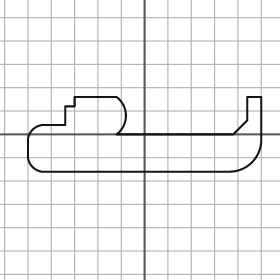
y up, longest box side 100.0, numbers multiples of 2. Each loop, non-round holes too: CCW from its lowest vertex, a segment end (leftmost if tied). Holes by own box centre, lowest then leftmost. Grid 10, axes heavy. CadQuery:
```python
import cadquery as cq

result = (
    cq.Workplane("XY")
    .moveTo(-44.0, -16.0)
    .lineTo(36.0, -16.0)
    .threePointArc((46.0, -12.0), (50.0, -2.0))
    .lineTo(50.0, 16.0)
    .lineTo(44.0, 16.0)
    .lineTo(44.0, 6.0)
    .lineTo(38.0, 0.0)
    .lineTo(-12.0, 0.0)
    .threePointArc((-8.0, 8.0), (-12.0, 16.0))
    .lineTo(-30.0, 16.0)
    .lineTo(-30.0, 12.0)
    .lineTo(-34.0, 12.0)
    .lineTo(-34.0, 4.0)
    .lineTo(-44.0, 4.0)
    .threePointArc((-48.0, 2.0), (-50.0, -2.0))
    .lineTo(-50.0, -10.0)
    .threePointArc((-48.0, -14.0), (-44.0, -16.0))
    .close()
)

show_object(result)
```